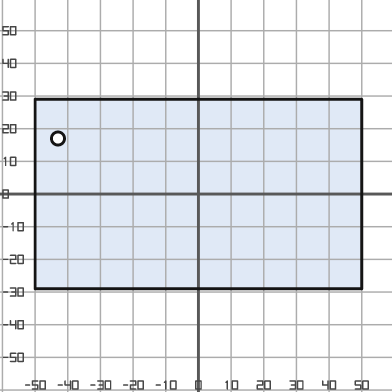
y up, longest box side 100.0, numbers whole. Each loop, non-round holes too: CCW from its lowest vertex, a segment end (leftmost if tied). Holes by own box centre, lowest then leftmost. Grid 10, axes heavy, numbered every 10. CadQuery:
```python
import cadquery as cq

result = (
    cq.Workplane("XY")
    .moveTo(-50.0, -29.0)
    .lineTo(50.0, -29.0)
    .lineTo(50.0, 29.0)
    .lineTo(-50.0, 29.0)
    .close()
    .moveTo(-43.0, 17.0)
    .circle(2.0)
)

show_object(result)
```